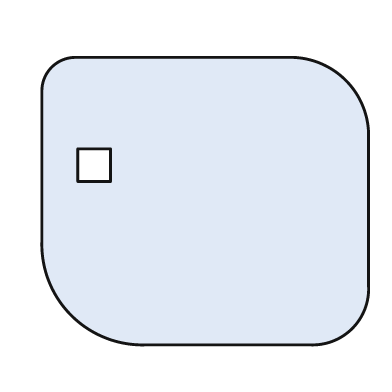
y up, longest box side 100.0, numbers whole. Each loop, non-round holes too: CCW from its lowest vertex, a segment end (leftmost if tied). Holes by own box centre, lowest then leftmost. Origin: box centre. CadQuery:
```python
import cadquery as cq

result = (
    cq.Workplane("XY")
    .moveTo(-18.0, -44.0)
    .lineTo(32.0, -44.0)
    .threePointArc((45.0, -39.0), (50.0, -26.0))
    .lineTo(50.0, 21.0)
    .threePointArc((43.0, 37.0), (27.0, 44.0))
    .lineTo(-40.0, 44.0)
    .threePointArc((-47.0, 41.0), (-50.0, 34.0))
    .lineTo(-50.0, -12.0)
    .threePointArc((-41.0, -35.0), (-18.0, -44.0))
    .close()
    .moveTo(-39.0, 6.0)
    .lineTo(-29.0, 6.0)
    .lineTo(-29.0, 16.0)
    .lineTo(-39.0, 16.0)
    .close()
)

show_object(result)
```